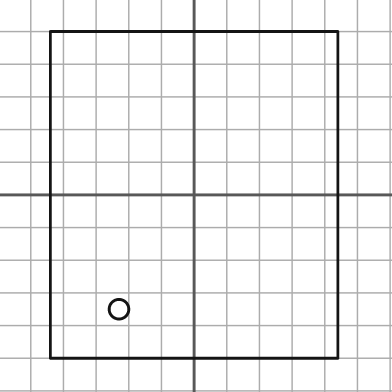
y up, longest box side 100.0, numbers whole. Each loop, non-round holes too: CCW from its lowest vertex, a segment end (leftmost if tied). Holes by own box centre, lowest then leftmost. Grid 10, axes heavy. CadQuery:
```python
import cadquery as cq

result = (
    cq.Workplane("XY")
    .moveTo(-44.0, -50.0)
    .lineTo(44.0, -50.0)
    .lineTo(44.0, 50.0)
    .lineTo(-44.0, 50.0)
    .close()
    .moveTo(-23.0, -35.0)
    .circle(3.0)
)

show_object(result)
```